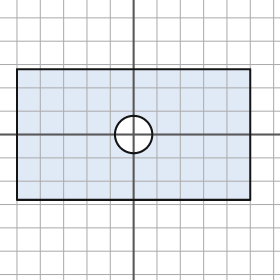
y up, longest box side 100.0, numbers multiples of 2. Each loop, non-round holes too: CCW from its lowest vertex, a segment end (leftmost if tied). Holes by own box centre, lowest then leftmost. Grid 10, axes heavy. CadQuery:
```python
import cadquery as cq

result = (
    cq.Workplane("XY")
    .moveTo(-50.0, -28.0)
    .lineTo(50.0, -28.0)
    .lineTo(50.0, 28.0)
    .lineTo(-50.0, 28.0)
    .close()
    .moveTo(0.0, 0.0)
    .circle(8.0)
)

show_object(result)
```